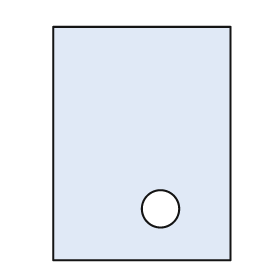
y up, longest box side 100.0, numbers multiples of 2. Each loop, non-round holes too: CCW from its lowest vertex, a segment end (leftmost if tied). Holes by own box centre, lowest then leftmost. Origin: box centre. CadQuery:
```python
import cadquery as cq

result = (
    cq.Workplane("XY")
    .moveTo(-38.0, -50.0)
    .lineTo(38.0, -50.0)
    .lineTo(38.0, 50.0)
    .lineTo(-38.0, 50.0)
    .close()
    .moveTo(8.0, -28.0)
    .circle(8.0)
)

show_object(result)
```